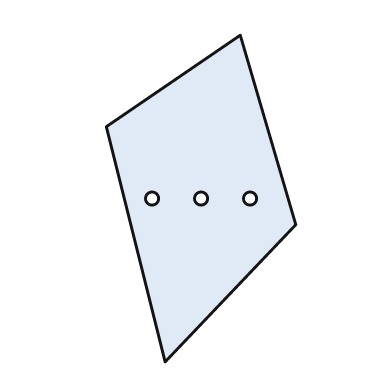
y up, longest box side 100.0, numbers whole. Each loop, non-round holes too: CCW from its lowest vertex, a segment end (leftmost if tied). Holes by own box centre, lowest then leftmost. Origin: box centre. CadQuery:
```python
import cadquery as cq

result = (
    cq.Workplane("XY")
    .moveTo(-11.0, -50.0)
    .lineTo(29.0, -8.0)
    .lineTo(12.0, 50.0)
    .lineTo(-29.0, 22.0)
    .close()
    .moveTo(-15.0, 0.0)
    .circle(2.0)
    .moveTo(0.0, 0.0)
    .circle(2.0)
    .moveTo(15.0, 0.0)
    .circle(2.0)
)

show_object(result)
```